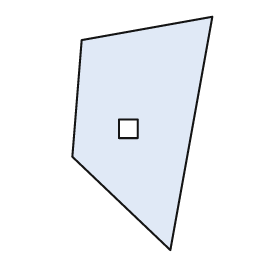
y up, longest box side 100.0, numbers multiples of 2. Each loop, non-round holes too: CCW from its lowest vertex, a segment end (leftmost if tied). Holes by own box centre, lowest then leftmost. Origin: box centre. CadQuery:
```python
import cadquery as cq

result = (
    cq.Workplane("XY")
    .moveTo(12.0, -50.0)
    .lineTo(30.0, 50.0)
    .lineTo(-26.0, 40.0)
    .lineTo(-30.0, -10.0)
    .close()
    .moveTo(-10.0, -2.0)
    .lineTo(-2.0, -2.0)
    .lineTo(-2.0, 6.0)
    .lineTo(-10.0, 6.0)
    .close()
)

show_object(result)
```